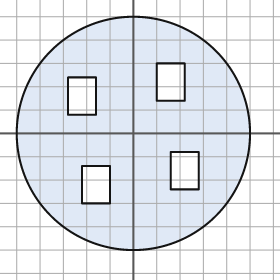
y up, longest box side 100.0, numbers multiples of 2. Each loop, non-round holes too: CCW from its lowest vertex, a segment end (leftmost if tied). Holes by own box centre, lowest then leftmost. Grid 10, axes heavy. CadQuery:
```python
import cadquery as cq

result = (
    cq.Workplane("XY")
    .moveTo(0.0, 0.0)
    .circle(50.0)
    .moveTo(-22.0, -30.0)
    .lineTo(-10.0, -30.0)
    .lineTo(-10.0, -14.0)
    .lineTo(-22.0, -14.0)
    .close()
    .moveTo(16.0, -24.0)
    .lineTo(28.0, -24.0)
    .lineTo(28.0, -8.0)
    .lineTo(16.0, -8.0)
    .close()
    .moveTo(-28.0, 8.0)
    .lineTo(-16.0, 8.0)
    .lineTo(-16.0, 24.0)
    .lineTo(-28.0, 24.0)
    .close()
    .moveTo(10.0, 14.0)
    .lineTo(22.0, 14.0)
    .lineTo(22.0, 30.0)
    .lineTo(10.0, 30.0)
    .close()
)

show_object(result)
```